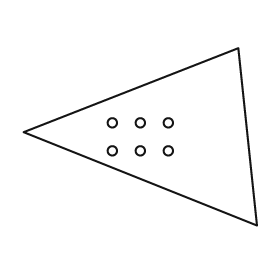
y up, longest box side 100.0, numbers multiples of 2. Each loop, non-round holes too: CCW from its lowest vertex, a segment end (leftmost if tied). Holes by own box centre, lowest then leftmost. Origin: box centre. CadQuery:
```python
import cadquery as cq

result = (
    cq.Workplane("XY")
    .moveTo(50.0, -38.0)
    .lineTo(42.0, 38.0)
    .lineTo(-50.0, 2.0)
    .close()
    .moveTo(-12.0, -6.0)
    .circle(2.0)
    .moveTo(0.0, -6.0)
    .circle(2.0)
    .moveTo(12.0, -6.0)
    .circle(2.0)
    .moveTo(-12.0, 6.0)
    .circle(2.0)
    .moveTo(0.0, 6.0)
    .circle(2.0)
    .moveTo(12.0, 6.0)
    .circle(2.0)
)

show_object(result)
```